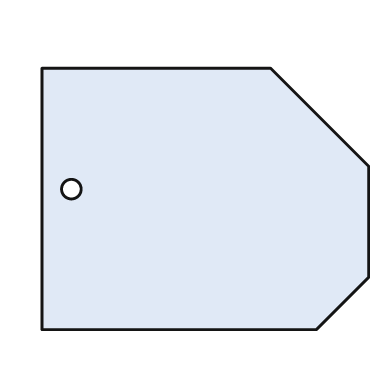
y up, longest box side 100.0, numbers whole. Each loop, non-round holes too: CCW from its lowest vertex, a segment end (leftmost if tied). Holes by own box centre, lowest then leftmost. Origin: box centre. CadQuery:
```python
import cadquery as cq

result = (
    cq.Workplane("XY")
    .moveTo(-50.0, -40.0)
    .lineTo(34.0, -40.0)
    .lineTo(50.0, -24.0)
    .lineTo(50.0, 10.0)
    .lineTo(20.0, 40.0)
    .lineTo(-50.0, 40.0)
    .close()
    .moveTo(-41.0, 3.0)
    .circle(3.0)
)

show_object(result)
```